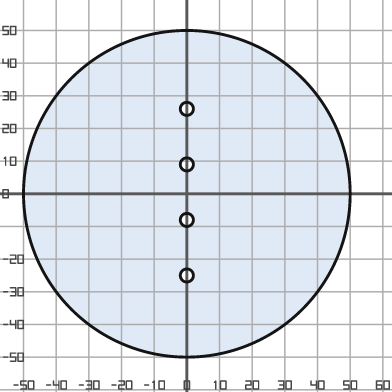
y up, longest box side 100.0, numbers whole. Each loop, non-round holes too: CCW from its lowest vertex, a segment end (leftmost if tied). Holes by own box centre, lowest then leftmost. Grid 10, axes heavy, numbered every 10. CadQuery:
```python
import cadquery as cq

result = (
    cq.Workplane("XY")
    .moveTo(0.0, 0.0)
    .circle(50.0)
    .moveTo(0.0, -25.0)
    .circle(2.0)
    .moveTo(0.0, -8.0)
    .circle(2.0)
    .moveTo(0.0, 9.0)
    .circle(2.0)
    .moveTo(0.0, 26.0)
    .circle(2.0)
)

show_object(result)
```